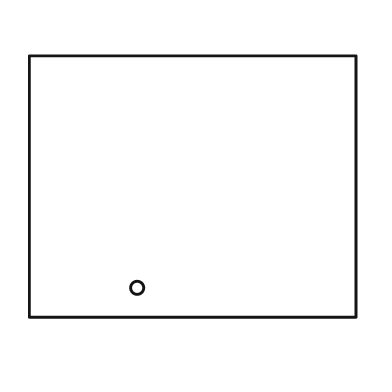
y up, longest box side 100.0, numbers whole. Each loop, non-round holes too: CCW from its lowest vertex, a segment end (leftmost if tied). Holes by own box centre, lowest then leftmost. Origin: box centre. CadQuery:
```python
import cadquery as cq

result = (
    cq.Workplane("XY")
    .moveTo(-50.0, -40.0)
    .lineTo(50.0, -40.0)
    .lineTo(50.0, 40.0)
    .lineTo(-50.0, 40.0)
    .close()
    .moveTo(-17.0, -31.0)
    .circle(2.0)
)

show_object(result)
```